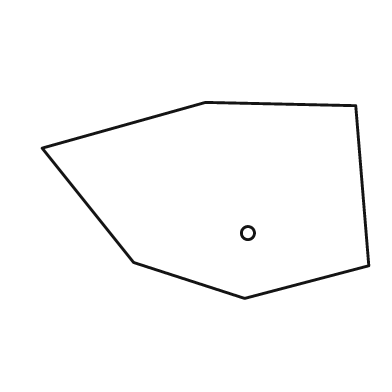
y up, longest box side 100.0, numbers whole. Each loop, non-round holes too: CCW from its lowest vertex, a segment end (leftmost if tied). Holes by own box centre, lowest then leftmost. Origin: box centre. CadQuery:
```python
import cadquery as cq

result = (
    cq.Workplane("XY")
    .moveTo(12.0, -30.0)
    .lineTo(50.0, -20.0)
    .lineTo(46.0, 29.0)
    .lineTo(0.0, 30.0)
    .lineTo(-50.0, 16.0)
    .lineTo(-22.0, -19.0)
    .close()
    .moveTo(13.0, -10.0)
    .circle(2.0)
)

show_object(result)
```